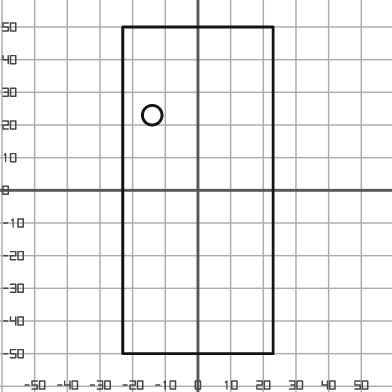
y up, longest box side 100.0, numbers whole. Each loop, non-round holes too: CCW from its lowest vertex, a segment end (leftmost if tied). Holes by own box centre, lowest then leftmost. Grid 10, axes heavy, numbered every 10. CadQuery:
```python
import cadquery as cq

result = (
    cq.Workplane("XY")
    .moveTo(-23.0, -50.0)
    .lineTo(23.0, -50.0)
    .lineTo(23.0, 50.0)
    .lineTo(-23.0, 50.0)
    .close()
    .moveTo(-14.0, 23.0)
    .circle(3.0)
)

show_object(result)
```